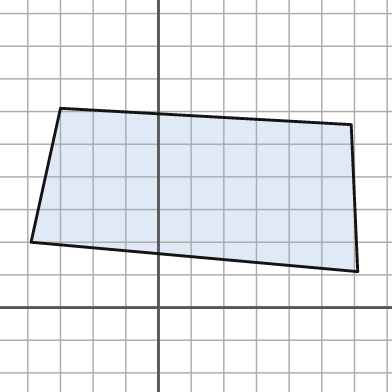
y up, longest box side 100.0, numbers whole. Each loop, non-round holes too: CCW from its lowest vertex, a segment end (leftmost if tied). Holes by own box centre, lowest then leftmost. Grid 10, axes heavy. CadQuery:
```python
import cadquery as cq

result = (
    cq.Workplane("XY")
    .moveTo(61.0, 11.0)
    .lineTo(59.0, 56.0)
    .lineTo(-30.0, 61.0)
    .lineTo(-39.0, 20.0)
    .close()
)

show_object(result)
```